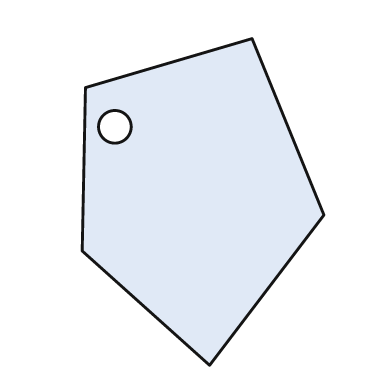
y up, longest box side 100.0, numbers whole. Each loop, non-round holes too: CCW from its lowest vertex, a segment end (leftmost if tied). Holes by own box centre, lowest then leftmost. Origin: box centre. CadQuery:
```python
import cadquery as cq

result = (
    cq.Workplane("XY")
    .moveTo(2.0, -50.0)
    .lineTo(37.0, -4.0)
    .lineTo(15.0, 50.0)
    .lineTo(-36.0, 35.0)
    .lineTo(-37.0, -15.0)
    .close()
    .moveTo(-27.0, 23.0)
    .circle(5.0)
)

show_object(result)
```